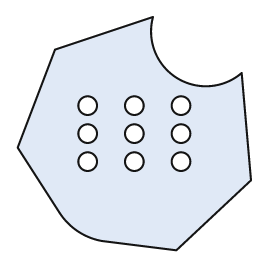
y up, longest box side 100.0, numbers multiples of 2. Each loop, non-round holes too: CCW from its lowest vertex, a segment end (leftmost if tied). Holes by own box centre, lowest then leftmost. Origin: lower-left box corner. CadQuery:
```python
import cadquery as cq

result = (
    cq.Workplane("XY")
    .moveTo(68.0, 0.0)
    .lineTo(100.0, 30.0)
    .lineTo(96.0, 76.0)
    .threePointArc((68.0, 74.0), (58.0, 100.0))
    .lineTo(16.0, 86.0)
    .lineTo(0.0, 44.0)
    .lineTo(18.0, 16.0)
    .threePointArc((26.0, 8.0), (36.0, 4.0))
    .close()
    .moveTo(30.0, 38.0)
    .circle(4.0)
    .moveTo(50.0, 38.0)
    .circle(4.0)
    .moveTo(70.0, 38.0)
    .circle(4.0)
    .moveTo(30.0, 50.0)
    .circle(4.0)
    .moveTo(50.0, 50.0)
    .circle(4.0)
    .moveTo(70.0, 50.0)
    .circle(4.0)
    .moveTo(30.0, 62.0)
    .circle(4.0)
    .moveTo(50.0, 62.0)
    .circle(4.0)
    .moveTo(70.0, 62.0)
    .circle(4.0)
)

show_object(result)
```